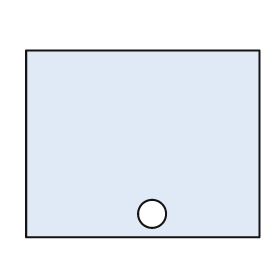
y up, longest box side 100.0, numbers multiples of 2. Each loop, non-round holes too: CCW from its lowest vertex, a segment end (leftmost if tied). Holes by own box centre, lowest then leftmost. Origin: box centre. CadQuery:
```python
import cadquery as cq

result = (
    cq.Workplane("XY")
    .moveTo(-50.0, -40.0)
    .lineTo(50.0, -40.0)
    .lineTo(50.0, 40.0)
    .lineTo(-50.0, 40.0)
    .close()
    .moveTo(4.0, -30.0)
    .circle(6.0)
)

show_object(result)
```